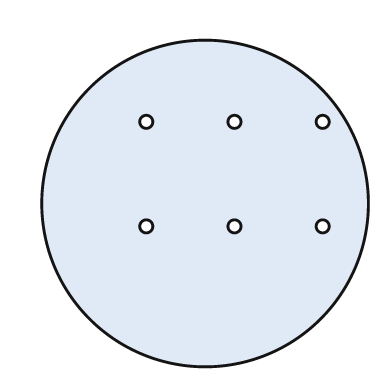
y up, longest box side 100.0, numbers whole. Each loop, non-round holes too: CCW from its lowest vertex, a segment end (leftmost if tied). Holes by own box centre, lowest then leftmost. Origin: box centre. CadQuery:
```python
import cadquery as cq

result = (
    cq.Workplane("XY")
    .moveTo(0.0, 0.0)
    .circle(50.0)
    .moveTo(-18.0, -7.0)
    .circle(2.0)
    .moveTo(9.0, -7.0)
    .circle(2.0)
    .moveTo(36.0, -7.0)
    .circle(2.0)
    .moveTo(-18.0, 25.0)
    .circle(2.0)
    .moveTo(9.0, 25.0)
    .circle(2.0)
    .moveTo(36.0, 25.0)
    .circle(2.0)
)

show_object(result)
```